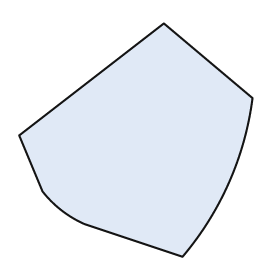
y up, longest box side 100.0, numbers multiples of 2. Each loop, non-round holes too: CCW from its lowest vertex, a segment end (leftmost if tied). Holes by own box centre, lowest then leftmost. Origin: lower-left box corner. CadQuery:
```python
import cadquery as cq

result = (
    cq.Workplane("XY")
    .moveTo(70.0, 0.0)
    .threePointArc((90.0, 32.0), (100.0, 68.0))
    .lineTo(62.0, 100.0)
    .lineTo(0.0, 52.0)
    .lineTo(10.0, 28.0)
    .threePointArc((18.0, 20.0), (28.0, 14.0))
    .close()
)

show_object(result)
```